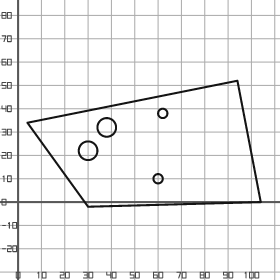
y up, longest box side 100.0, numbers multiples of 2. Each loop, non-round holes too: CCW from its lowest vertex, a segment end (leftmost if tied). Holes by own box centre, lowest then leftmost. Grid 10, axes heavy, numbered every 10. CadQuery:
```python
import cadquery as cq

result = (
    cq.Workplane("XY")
    .moveTo(30.0, -2.0)
    .lineTo(104.0, 0.0)
    .lineTo(94.0, 52.0)
    .lineTo(4.0, 34.0)
    .close()
    .moveTo(60.0, 10.0)
    .circle(2.0)
    .moveTo(30.0, 22.0)
    .circle(4.0)
    .moveTo(38.0, 32.0)
    .circle(4.0)
    .moveTo(62.0, 38.0)
    .circle(2.0)
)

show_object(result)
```